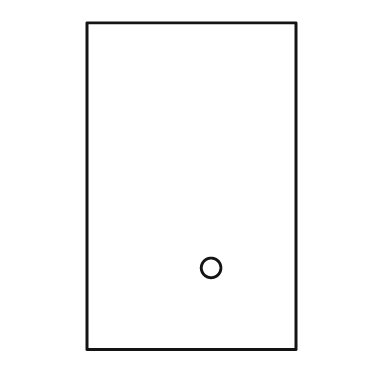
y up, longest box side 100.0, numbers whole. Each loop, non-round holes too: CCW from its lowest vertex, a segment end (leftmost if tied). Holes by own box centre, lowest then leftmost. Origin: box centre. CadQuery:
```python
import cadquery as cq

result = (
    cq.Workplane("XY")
    .moveTo(-32.0, -50.0)
    .lineTo(32.0, -50.0)
    .lineTo(32.0, 50.0)
    .lineTo(-32.0, 50.0)
    .close()
    .moveTo(6.0, -25.0)
    .circle(3.0)
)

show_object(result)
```